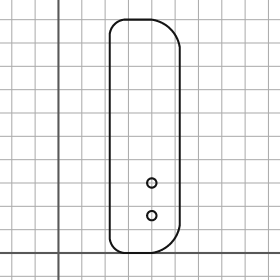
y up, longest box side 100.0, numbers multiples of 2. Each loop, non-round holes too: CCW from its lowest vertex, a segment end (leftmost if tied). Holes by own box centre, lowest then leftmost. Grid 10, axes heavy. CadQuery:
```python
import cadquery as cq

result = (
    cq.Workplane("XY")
    .moveTo(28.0, 0.0)
    .lineTo(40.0, 0.0)
    .threePointArc((48.0, 4.0), (52.0, 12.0))
    .lineTo(52.0, 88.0)
    .threePointArc((48.0, 96.0), (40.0, 100.0))
    .lineTo(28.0, 100.0)
    .threePointArc((24.0, 98.0), (22.0, 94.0))
    .lineTo(22.0, 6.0)
    .threePointArc((24.0, 2.0), (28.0, 0.0))
    .close()
    .moveTo(40.0, 16.0)
    .circle(2.0)
    .moveTo(40.0, 30.0)
    .circle(2.0)
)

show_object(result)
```